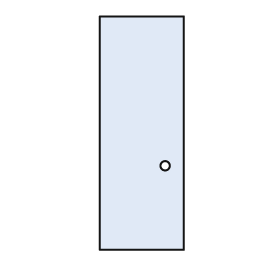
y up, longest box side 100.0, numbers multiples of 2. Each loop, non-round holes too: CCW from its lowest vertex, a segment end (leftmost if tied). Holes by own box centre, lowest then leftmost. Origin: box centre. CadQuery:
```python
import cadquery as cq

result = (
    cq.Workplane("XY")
    .moveTo(-18.0, -50.0)
    .lineTo(18.0, -50.0)
    .lineTo(18.0, 50.0)
    .lineTo(-18.0, 50.0)
    .close()
    .moveTo(10.0, -14.0)
    .circle(2.0)
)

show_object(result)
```